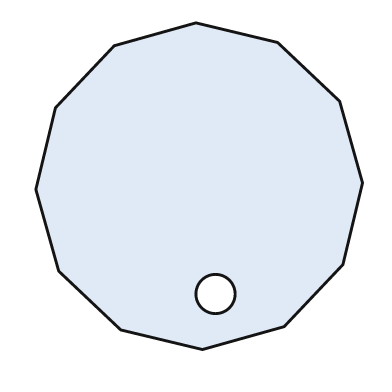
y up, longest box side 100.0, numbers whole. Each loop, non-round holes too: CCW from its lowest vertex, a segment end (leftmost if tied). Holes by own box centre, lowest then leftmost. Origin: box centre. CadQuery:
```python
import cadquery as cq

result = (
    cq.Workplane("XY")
    .moveTo(1.0, -50.0)
    .lineTo(26.0, -43.0)
    .lineTo(44.0, -24.0)
    .lineTo(50.0, 1.0)
    .lineTo(43.0, 26.0)
    .lineTo(24.0, 44.0)
    .lineTo(-1.0, 50.0)
    .lineTo(-26.0, 43.0)
    .lineTo(-44.0, 24.0)
    .lineTo(-50.0, -1.0)
    .lineTo(-43.0, -26.0)
    .lineTo(-24.0, -44.0)
    .close()
    .moveTo(5.0, -33.0)
    .circle(6.0)
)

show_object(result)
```